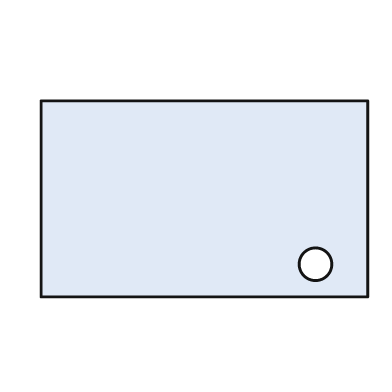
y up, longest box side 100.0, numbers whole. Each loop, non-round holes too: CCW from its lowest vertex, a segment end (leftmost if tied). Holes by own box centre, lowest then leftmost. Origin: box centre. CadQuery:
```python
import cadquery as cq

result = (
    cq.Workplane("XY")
    .moveTo(-50.0, -30.0)
    .lineTo(50.0, -30.0)
    .lineTo(50.0, 30.0)
    .lineTo(-50.0, 30.0)
    .close()
    .moveTo(34.0, -20.0)
    .circle(5.0)
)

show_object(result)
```